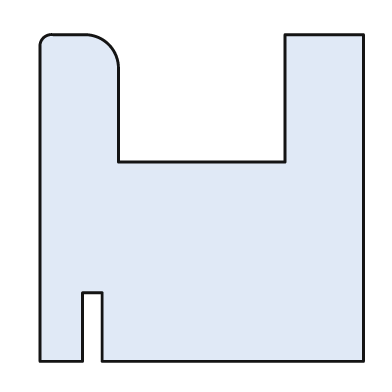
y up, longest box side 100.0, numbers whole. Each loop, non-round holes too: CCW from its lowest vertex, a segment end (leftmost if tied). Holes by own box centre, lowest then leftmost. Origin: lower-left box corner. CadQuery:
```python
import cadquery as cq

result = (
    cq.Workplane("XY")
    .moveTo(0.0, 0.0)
    .lineTo(13.0, 0.0)
    .lineTo(13.0, 21.0)
    .lineTo(19.0, 21.0)
    .lineTo(19.0, 0.0)
    .lineTo(99.0, 0.0)
    .lineTo(99.0, 100.0)
    .lineTo(75.0, 100.0)
    .lineTo(75.0, 61.0)
    .lineTo(24.0, 61.0)
    .lineTo(24.0, 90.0)
    .threePointArc((21.0, 97.0), (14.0, 100.0))
    .lineTo(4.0, 100.0)
    .threePointArc((1.0, 99.0), (0.0, 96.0))
    .close()
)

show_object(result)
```